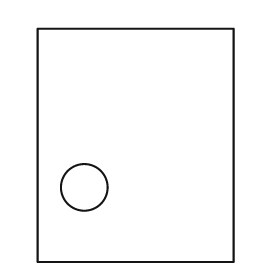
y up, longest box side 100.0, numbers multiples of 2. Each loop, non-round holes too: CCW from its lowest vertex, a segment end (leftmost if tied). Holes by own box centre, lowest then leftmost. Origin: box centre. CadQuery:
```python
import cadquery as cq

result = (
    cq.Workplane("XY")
    .moveTo(-42.0, -50.0)
    .lineTo(42.0, -50.0)
    .lineTo(42.0, 50.0)
    .lineTo(-42.0, 50.0)
    .close()
    .moveTo(-22.0, -18.0)
    .circle(10.0)
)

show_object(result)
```